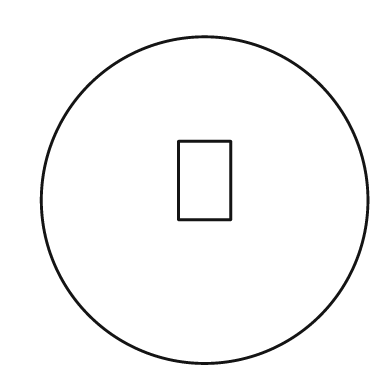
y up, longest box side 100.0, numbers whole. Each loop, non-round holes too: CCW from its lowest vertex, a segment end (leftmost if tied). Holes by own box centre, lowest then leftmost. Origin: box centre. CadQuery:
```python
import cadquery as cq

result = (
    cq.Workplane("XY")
    .moveTo(0.0, 0.0)
    .circle(50.0)
    .moveTo(-8.0, -6.0)
    .lineTo(8.0, -6.0)
    .lineTo(8.0, 18.0)
    .lineTo(-8.0, 18.0)
    .close()
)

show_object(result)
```